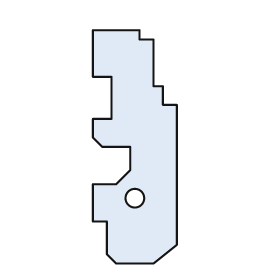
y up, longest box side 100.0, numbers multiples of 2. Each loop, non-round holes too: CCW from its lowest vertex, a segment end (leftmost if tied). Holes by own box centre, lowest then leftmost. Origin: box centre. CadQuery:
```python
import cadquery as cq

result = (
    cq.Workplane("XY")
    .moveTo(-8.0, -50.0)
    .lineTo(8.0, -50.0)
    .lineTo(18.0, -42.0)
    .lineTo(18.0, 18.0)
    .lineTo(12.0, 18.0)
    .lineTo(12.0, 26.0)
    .lineTo(8.0, 26.0)
    .lineTo(8.0, 46.0)
    .lineTo(2.0, 46.0)
    .lineTo(2.0, 50.0)
    .lineTo(-18.0, 50.0)
    .lineTo(-18.0, 30.0)
    .lineTo(-10.0, 30.0)
    .lineTo(-10.0, 12.0)
    .lineTo(-18.0, 12.0)
    .lineTo(-18.0, 4.0)
    .lineTo(-14.0, 0.0)
    .lineTo(-2.0, 0.0)
    .lineTo(-2.0, -10.0)
    .lineTo(-8.0, -16.0)
    .lineTo(-18.0, -16.0)
    .lineTo(-18.0, -32.0)
    .lineTo(-12.0, -32.0)
    .lineTo(-12.0, -46.0)
    .close()
    .moveTo(0.0, -22.0)
    .circle(4.0)
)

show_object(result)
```